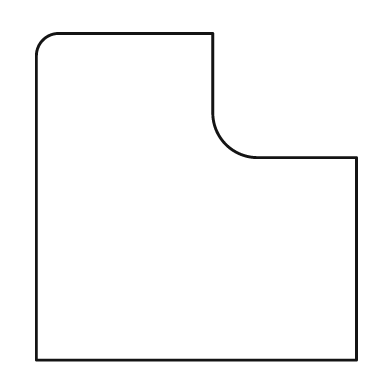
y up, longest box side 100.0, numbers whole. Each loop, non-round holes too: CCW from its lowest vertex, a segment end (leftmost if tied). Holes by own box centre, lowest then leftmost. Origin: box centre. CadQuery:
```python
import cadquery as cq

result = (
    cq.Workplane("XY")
    .moveTo(-49.0, -50.0)
    .lineTo(49.0, -50.0)
    .lineTo(49.0, 12.0)
    .lineTo(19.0, 12.0)
    .threePointArc((9.0, 16.0), (5.0, 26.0))
    .lineTo(5.0, 50.0)
    .lineTo(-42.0, 50.0)
    .threePointArc((-47.0, 48.0), (-49.0, 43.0))
    .close()
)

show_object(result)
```